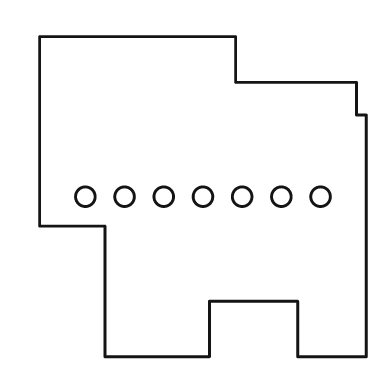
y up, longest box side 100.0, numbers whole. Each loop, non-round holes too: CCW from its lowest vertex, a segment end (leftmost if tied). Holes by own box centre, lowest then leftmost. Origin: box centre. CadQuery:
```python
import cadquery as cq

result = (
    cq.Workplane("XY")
    .moveTo(-30.0, -49.0)
    .lineTo(2.0, -49.0)
    .lineTo(2.0, -32.0)
    .lineTo(29.0, -32.0)
    .lineTo(29.0, -49.0)
    .lineTo(50.0, -49.0)
    .lineTo(50.0, 25.0)
    .lineTo(47.0, 25.0)
    .lineTo(47.0, 35.0)
    .lineTo(10.0, 35.0)
    .lineTo(10.0, 49.0)
    .lineTo(-50.0, 49.0)
    .lineTo(-50.0, -9.0)
    .lineTo(-30.0, -9.0)
    .close()
    .moveTo(-36.0, 0.0)
    .circle(3.0)
    .moveTo(-24.0, 0.0)
    .circle(3.0)
    .moveTo(-12.0, 0.0)
    .circle(3.0)
    .moveTo(0.0, 0.0)
    .circle(3.0)
    .moveTo(12.0, 0.0)
    .circle(3.0)
    .moveTo(24.0, 0.0)
    .circle(3.0)
    .moveTo(36.0, 0.0)
    .circle(3.0)
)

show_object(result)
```